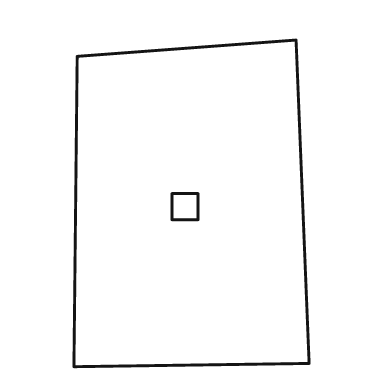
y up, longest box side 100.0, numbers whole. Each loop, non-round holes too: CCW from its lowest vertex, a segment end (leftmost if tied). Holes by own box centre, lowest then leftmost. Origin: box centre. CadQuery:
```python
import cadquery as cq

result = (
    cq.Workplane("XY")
    .moveTo(-36.0, -50.0)
    .lineTo(36.0, -49.0)
    .lineTo(32.0, 50.0)
    .lineTo(-35.0, 45.0)
    .close()
    .moveTo(-6.0, -5.0)
    .lineTo(2.0, -5.0)
    .lineTo(2.0, 3.0)
    .lineTo(-6.0, 3.0)
    .close()
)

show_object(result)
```